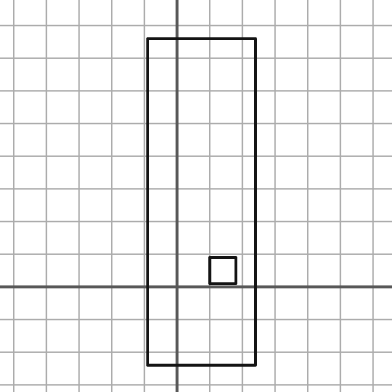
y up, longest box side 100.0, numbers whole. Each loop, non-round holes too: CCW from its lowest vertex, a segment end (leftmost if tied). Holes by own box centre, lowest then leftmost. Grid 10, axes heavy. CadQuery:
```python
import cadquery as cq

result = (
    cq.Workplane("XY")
    .moveTo(-9.0, -24.0)
    .lineTo(24.0, -24.0)
    .lineTo(24.0, 76.0)
    .lineTo(-9.0, 76.0)
    .close()
    .moveTo(10.0, 1.0)
    .lineTo(18.0, 1.0)
    .lineTo(18.0, 9.0)
    .lineTo(10.0, 9.0)
    .close()
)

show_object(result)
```